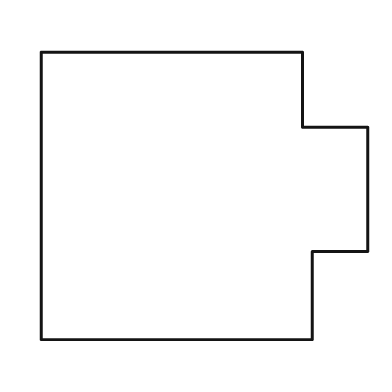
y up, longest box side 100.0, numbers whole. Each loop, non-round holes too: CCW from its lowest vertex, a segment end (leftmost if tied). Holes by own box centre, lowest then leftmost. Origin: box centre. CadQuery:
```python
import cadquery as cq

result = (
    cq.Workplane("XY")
    .moveTo(-50.0, -44.0)
    .lineTo(33.0, -44.0)
    .lineTo(33.0, -17.0)
    .lineTo(50.0, -17.0)
    .lineTo(50.0, 21.0)
    .lineTo(30.0, 21.0)
    .lineTo(30.0, 44.0)
    .lineTo(-50.0, 44.0)
    .close()
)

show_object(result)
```